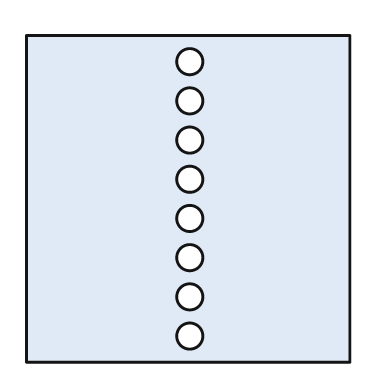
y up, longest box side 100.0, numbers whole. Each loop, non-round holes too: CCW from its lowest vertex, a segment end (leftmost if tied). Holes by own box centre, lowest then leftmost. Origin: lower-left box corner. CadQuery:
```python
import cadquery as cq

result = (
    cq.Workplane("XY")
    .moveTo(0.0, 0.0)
    .lineTo(99.0, 0.0)
    .lineTo(99.0, 100.0)
    .lineTo(0.0, 100.0)
    .close()
    .moveTo(50.0, 8.0)
    .circle(4.0)
    .moveTo(50.0, 20.0)
    .circle(4.0)
    .moveTo(50.0, 32.0)
    .circle(4.0)
    .moveTo(50.0, 44.0)
    .circle(4.0)
    .moveTo(50.0, 56.0)
    .circle(4.0)
    .moveTo(50.0, 68.0)
    .circle(4.0)
    .moveTo(50.0, 80.0)
    .circle(4.0)
    .moveTo(50.0, 92.0)
    .circle(4.0)
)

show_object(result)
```